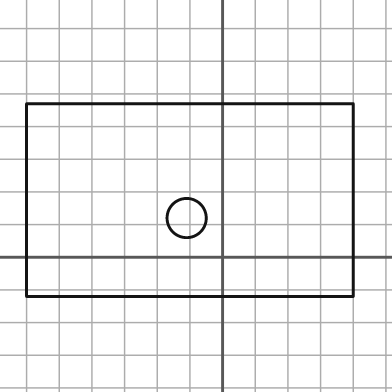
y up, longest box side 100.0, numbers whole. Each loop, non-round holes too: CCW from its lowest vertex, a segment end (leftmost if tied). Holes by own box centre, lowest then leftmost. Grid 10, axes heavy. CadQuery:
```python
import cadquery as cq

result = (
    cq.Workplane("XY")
    .moveTo(-60.0, -12.0)
    .lineTo(40.0, -12.0)
    .lineTo(40.0, 47.0)
    .lineTo(-60.0, 47.0)
    .close()
    .moveTo(-11.0, 12.0)
    .circle(6.0)
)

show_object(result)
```